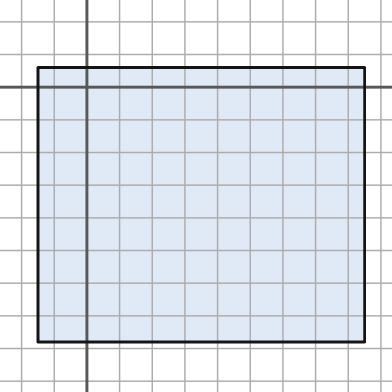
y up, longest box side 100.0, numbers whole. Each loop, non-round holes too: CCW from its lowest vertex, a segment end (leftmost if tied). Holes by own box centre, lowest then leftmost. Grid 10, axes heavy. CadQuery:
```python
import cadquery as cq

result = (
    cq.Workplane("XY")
    .moveTo(-15.0, -78.0)
    .lineTo(85.0, -78.0)
    .lineTo(85.0, 6.0)
    .lineTo(-15.0, 6.0)
    .close()
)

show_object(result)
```